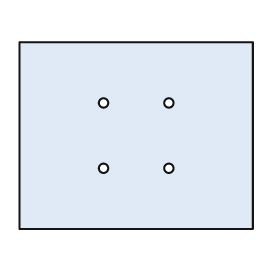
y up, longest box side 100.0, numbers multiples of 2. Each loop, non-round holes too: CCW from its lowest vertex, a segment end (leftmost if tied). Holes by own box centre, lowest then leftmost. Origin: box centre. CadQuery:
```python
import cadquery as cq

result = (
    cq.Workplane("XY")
    .moveTo(-50.0, -40.0)
    .lineTo(50.0, -40.0)
    .lineTo(50.0, 40.0)
    .lineTo(-50.0, 40.0)
    .close()
    .moveTo(-14.0, -14.0)
    .circle(2.0)
    .moveTo(14.0, -14.0)
    .circle(2.0)
    .moveTo(-14.0, 14.0)
    .circle(2.0)
    .moveTo(14.0, 14.0)
    .circle(2.0)
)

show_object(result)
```